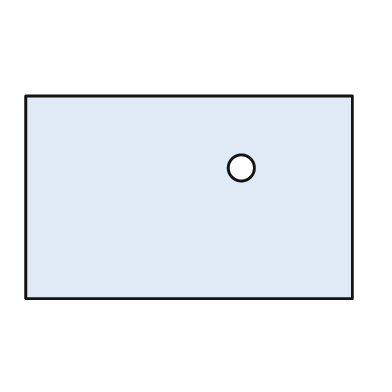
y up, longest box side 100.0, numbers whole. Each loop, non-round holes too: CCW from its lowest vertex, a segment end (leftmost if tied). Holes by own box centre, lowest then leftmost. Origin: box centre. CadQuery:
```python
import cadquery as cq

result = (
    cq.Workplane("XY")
    .moveTo(-50.0, -31.0)
    .lineTo(50.0, -31.0)
    .lineTo(50.0, 31.0)
    .lineTo(-50.0, 31.0)
    .close()
    .moveTo(16.0, 9.0)
    .circle(4.0)
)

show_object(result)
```